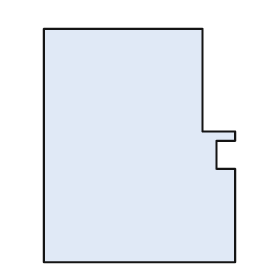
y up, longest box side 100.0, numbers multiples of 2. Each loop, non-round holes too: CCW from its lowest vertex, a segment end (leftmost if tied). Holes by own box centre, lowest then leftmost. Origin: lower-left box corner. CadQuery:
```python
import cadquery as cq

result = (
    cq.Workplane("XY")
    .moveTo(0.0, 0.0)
    .lineTo(82.0, 0.0)
    .lineTo(82.0, 40.0)
    .lineTo(74.0, 40.0)
    .lineTo(74.0, 52.0)
    .lineTo(82.0, 52.0)
    .lineTo(82.0, 56.0)
    .lineTo(68.0, 56.0)
    .lineTo(68.0, 100.0)
    .lineTo(0.0, 100.0)
    .close()
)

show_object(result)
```